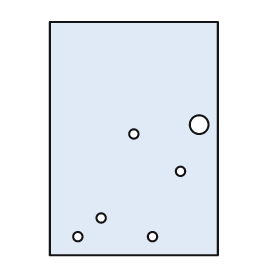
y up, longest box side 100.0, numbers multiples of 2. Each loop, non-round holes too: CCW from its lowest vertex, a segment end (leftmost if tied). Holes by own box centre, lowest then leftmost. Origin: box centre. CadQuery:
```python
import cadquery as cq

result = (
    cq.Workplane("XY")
    .moveTo(-36.0, -50.0)
    .lineTo(36.0, -50.0)
    .lineTo(36.0, 50.0)
    .lineTo(-36.0, 50.0)
    .close()
    .moveTo(-24.0, -42.0)
    .circle(2.0)
    .moveTo(8.0, -42.0)
    .circle(2.0)
    .moveTo(-14.0, -34.0)
    .circle(2.0)
    .moveTo(20.0, -14.0)
    .circle(2.0)
    .moveTo(0.0, 2.0)
    .circle(2.0)
    .moveTo(28.0, 6.0)
    .circle(4.0)
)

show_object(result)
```